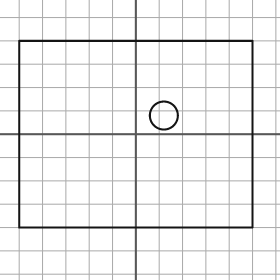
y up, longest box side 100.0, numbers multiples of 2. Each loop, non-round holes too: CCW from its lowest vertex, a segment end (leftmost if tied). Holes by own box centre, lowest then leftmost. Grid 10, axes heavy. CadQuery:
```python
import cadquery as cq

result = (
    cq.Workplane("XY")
    .moveTo(-50.0, -40.0)
    .lineTo(50.0, -40.0)
    .lineTo(50.0, 40.0)
    .lineTo(-50.0, 40.0)
    .close()
    .moveTo(12.0, 8.0)
    .circle(6.0)
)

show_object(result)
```